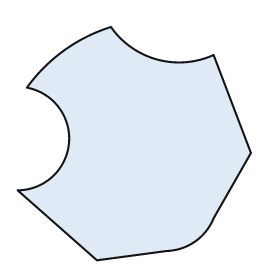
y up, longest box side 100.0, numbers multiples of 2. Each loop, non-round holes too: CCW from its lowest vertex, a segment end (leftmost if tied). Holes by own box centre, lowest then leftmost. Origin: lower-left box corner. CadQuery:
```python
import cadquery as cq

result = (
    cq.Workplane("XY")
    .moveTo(34.0, 0.0)
    .lineTo(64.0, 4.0)
    .threePointArc((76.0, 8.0), (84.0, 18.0))
    .lineTo(100.0, 46.0)
    .lineTo(84.0, 88.0)
    .threePointArc((60.0, 86.0), (40.0, 100.0))
    .threePointArc((20.0, 90.0), (4.0, 74.0))
    .threePointArc((22.0, 50.0), (0.0, 30.0))
    .close()
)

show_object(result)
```